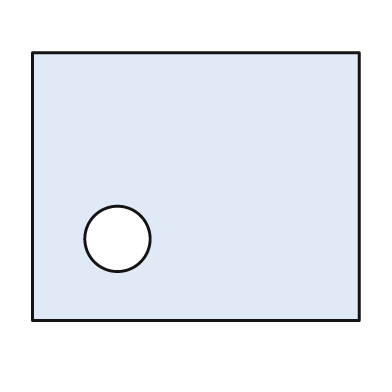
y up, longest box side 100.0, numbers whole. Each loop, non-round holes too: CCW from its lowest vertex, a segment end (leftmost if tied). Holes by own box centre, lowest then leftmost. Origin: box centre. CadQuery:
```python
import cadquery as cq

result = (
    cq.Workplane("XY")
    .moveTo(-50.0, -41.0)
    .lineTo(50.0, -41.0)
    .lineTo(50.0, 41.0)
    .lineTo(-50.0, 41.0)
    .close()
    .moveTo(-24.0, -16.0)
    .circle(10.0)
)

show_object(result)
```